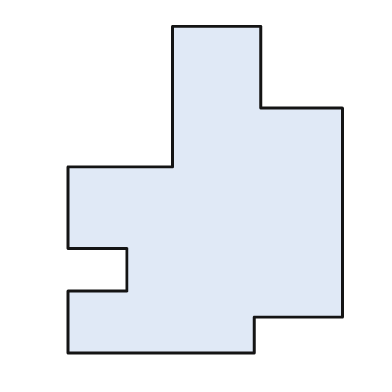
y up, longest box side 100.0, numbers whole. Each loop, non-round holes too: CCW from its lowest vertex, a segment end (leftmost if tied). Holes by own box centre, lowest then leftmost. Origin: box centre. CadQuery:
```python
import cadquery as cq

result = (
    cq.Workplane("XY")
    .moveTo(-42.0, -50.0)
    .lineTo(15.0, -50.0)
    .lineTo(15.0, -39.0)
    .lineTo(42.0, -39.0)
    .lineTo(42.0, 25.0)
    .lineTo(17.0, 25.0)
    .lineTo(17.0, 50.0)
    .lineTo(-10.0, 50.0)
    .lineTo(-10.0, 7.0)
    .lineTo(-42.0, 7.0)
    .lineTo(-42.0, -18.0)
    .lineTo(-24.0, -18.0)
    .lineTo(-24.0, -31.0)
    .lineTo(-42.0, -31.0)
    .close()
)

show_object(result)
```